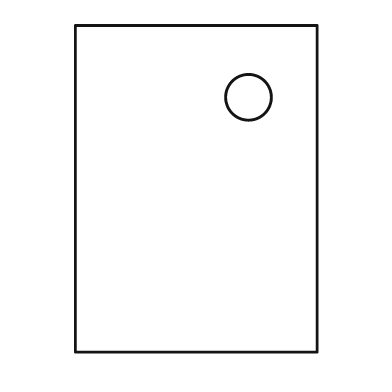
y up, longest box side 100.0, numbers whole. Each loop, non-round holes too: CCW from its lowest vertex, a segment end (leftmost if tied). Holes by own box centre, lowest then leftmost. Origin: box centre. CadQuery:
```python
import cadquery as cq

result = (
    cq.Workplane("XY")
    .moveTo(-37.0, -50.0)
    .lineTo(37.0, -50.0)
    .lineTo(37.0, 50.0)
    .lineTo(-37.0, 50.0)
    .close()
    .moveTo(16.0, 28.0)
    .circle(7.0)
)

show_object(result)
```